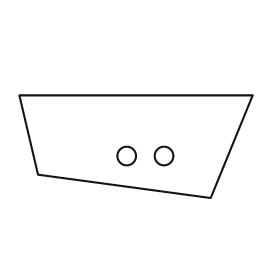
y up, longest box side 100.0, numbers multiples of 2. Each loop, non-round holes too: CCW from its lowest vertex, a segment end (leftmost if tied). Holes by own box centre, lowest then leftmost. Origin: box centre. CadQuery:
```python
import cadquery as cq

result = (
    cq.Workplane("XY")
    .moveTo(32.0, -22.0)
    .lineTo(50.0, 22.0)
    .lineTo(-50.0, 22.0)
    .lineTo(-42.0, -12.0)
    .close()
    .moveTo(-4.0, -4.0)
    .circle(4.0)
    .moveTo(12.0, -4.0)
    .circle(4.0)
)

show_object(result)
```